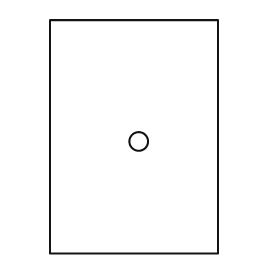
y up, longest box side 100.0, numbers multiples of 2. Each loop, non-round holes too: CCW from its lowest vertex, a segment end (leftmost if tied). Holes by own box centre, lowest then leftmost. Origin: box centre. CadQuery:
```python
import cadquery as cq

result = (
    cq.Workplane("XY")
    .moveTo(-36.0, -50.0)
    .lineTo(36.0, -50.0)
    .lineTo(36.0, 50.0)
    .lineTo(-36.0, 50.0)
    .close()
    .moveTo(2.0, -2.0)
    .circle(4.0)
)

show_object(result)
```